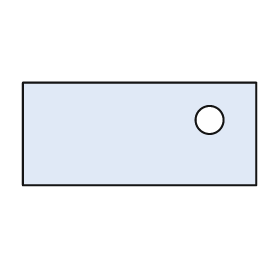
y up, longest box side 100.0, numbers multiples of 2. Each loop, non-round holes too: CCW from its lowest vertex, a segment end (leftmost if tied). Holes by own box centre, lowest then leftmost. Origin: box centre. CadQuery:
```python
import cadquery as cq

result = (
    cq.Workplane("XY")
    .moveTo(-50.0, -22.0)
    .lineTo(50.0, -22.0)
    .lineTo(50.0, 22.0)
    .lineTo(-50.0, 22.0)
    .close()
    .moveTo(30.0, 6.0)
    .circle(6.0)
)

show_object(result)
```